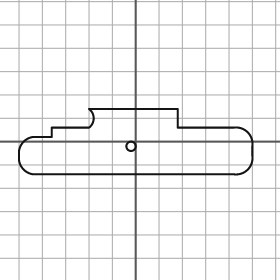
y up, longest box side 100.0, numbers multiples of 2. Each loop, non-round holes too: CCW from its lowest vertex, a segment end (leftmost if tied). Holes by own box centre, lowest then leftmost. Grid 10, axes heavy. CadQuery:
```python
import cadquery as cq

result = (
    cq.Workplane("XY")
    .moveTo(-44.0, -14.0)
    .lineTo(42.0, -14.0)
    .threePointArc((48.0, -12.0), (50.0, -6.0))
    .lineTo(50.0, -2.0)
    .threePointArc((48.0, 4.0), (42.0, 6.0))
    .lineTo(18.0, 6.0)
    .lineTo(18.0, 14.0)
    .lineTo(-20.0, 14.0)
    .threePointArc((-18.0, 10.0), (-20.0, 6.0))
    .lineTo(-36.0, 6.0)
    .lineTo(-36.0, 2.0)
    .lineTo(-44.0, 2.0)
    .threePointArc((-48.0, 0.0), (-50.0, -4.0))
    .lineTo(-50.0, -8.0)
    .threePointArc((-48.0, -12.0), (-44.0, -14.0))
    .close()
    .moveTo(-2.0, -2.0)
    .circle(2.0)
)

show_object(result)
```